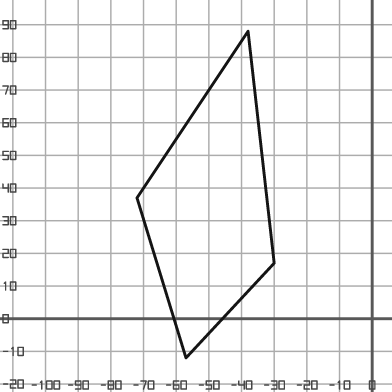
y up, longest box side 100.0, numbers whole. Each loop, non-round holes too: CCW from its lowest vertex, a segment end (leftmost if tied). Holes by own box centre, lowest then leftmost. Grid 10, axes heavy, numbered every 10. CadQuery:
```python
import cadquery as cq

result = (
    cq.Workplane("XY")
    .moveTo(-57.0, -12.0)
    .lineTo(-30.0, 17.0)
    .lineTo(-38.0, 88.0)
    .lineTo(-72.0, 37.0)
    .close()
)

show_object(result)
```